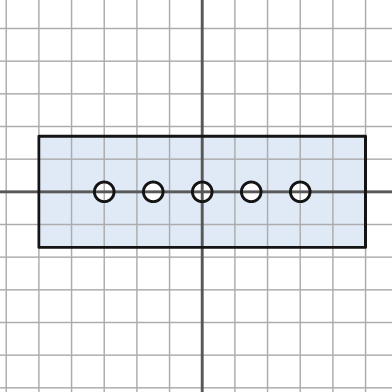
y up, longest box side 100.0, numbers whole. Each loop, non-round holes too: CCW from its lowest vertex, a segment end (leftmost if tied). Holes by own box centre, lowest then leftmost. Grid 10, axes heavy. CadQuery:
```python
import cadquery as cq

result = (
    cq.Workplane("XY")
    .moveTo(-50.0, -17.0)
    .lineTo(50.0, -17.0)
    .lineTo(50.0, 17.0)
    .lineTo(-50.0, 17.0)
    .close()
    .moveTo(-30.0, 0.0)
    .circle(3.0)
    .moveTo(-15.0, 0.0)
    .circle(3.0)
    .moveTo(0.0, 0.0)
    .circle(3.0)
    .moveTo(15.0, 0.0)
    .circle(3.0)
    .moveTo(30.0, 0.0)
    .circle(3.0)
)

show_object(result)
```